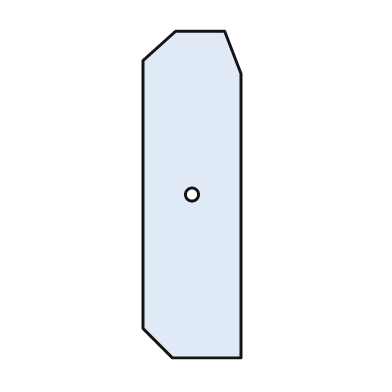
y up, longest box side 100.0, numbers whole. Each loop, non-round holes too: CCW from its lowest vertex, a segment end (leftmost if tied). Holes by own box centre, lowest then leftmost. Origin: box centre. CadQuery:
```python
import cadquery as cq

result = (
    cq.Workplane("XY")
    .moveTo(-6.0, -50.0)
    .lineTo(15.0, -50.0)
    .lineTo(15.0, 37.0)
    .lineTo(10.0, 50.0)
    .lineTo(-5.0, 50.0)
    .lineTo(-15.0, 41.0)
    .lineTo(-15.0, -41.0)
    .close()
    .moveTo(0.0, 0.0)
    .circle(2.0)
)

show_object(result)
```